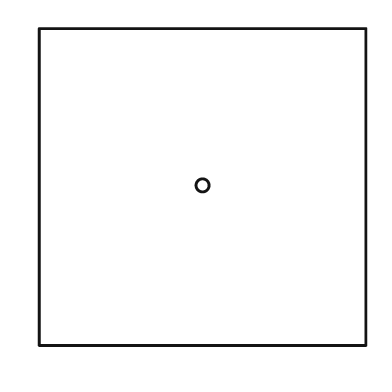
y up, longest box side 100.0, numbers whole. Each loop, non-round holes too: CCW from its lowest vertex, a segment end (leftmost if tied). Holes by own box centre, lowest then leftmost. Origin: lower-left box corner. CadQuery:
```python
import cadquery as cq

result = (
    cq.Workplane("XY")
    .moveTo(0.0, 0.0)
    .lineTo(100.0, 0.0)
    .lineTo(100.0, 97.0)
    .lineTo(0.0, 97.0)
    .close()
    .moveTo(50.0, 49.0)
    .circle(2.0)
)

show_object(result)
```